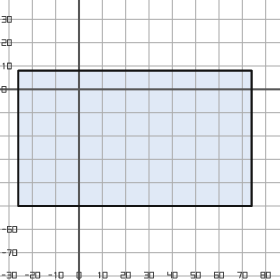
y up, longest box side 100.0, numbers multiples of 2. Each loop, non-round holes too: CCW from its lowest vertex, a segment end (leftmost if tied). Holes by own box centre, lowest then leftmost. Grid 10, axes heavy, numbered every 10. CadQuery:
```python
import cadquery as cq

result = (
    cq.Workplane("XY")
    .moveTo(-26.0, -50.0)
    .lineTo(74.0, -50.0)
    .lineTo(74.0, 8.0)
    .lineTo(-26.0, 8.0)
    .close()
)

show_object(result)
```